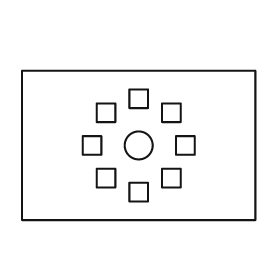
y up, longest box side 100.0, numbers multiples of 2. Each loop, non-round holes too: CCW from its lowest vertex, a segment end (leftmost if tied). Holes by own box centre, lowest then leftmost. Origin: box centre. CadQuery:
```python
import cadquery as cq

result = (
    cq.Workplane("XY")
    .moveTo(-50.0, -32.0)
    .lineTo(50.0, -32.0)
    .lineTo(50.0, 32.0)
    .lineTo(-50.0, 32.0)
    .close()
    .moveTo(-4.0, -24.0)
    .lineTo(4.0, -24.0)
    .lineTo(4.0, -16.0)
    .lineTo(-4.0, -16.0)
    .close()
    .moveTo(-18.0, -18.0)
    .lineTo(-10.0, -18.0)
    .lineTo(-10.0, -10.0)
    .lineTo(-18.0, -10.0)
    .close()
    .moveTo(10.0, -18.0)
    .lineTo(18.0, -18.0)
    .lineTo(18.0, -10.0)
    .lineTo(10.0, -10.0)
    .close()
    .moveTo(-24.0, -4.0)
    .lineTo(-16.0, -4.0)
    .lineTo(-16.0, 4.0)
    .lineTo(-24.0, 4.0)
    .close()
    .moveTo(0.0, 0.0)
    .circle(6.0)
    .moveTo(16.0, -4.0)
    .lineTo(24.0, -4.0)
    .lineTo(24.0, 4.0)
    .lineTo(16.0, 4.0)
    .close()
    .moveTo(-18.0, 10.0)
    .lineTo(-10.0, 10.0)
    .lineTo(-10.0, 18.0)
    .lineTo(-18.0, 18.0)
    .close()
    .moveTo(10.0, 10.0)
    .lineTo(18.0, 10.0)
    .lineTo(18.0, 18.0)
    .lineTo(10.0, 18.0)
    .close()
    .moveTo(-4.0, 16.0)
    .lineTo(4.0, 16.0)
    .lineTo(4.0, 24.0)
    .lineTo(-4.0, 24.0)
    .close()
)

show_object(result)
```